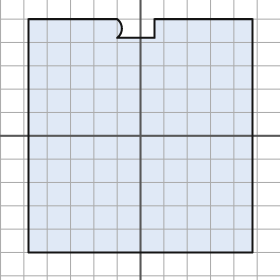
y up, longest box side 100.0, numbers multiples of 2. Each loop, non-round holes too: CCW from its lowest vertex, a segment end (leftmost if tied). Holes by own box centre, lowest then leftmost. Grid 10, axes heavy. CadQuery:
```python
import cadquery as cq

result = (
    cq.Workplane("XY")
    .moveTo(-48.0, -50.0)
    .lineTo(48.0, -50.0)
    .lineTo(48.0, 50.0)
    .lineTo(6.0, 50.0)
    .lineTo(6.0, 42.0)
    .lineTo(-10.0, 42.0)
    .threePointArc((-8.0, 46.0), (-10.0, 50.0))
    .lineTo(-48.0, 50.0)
    .close()
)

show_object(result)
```